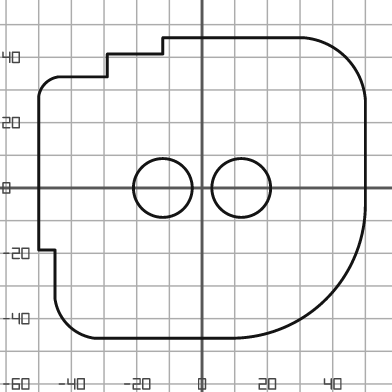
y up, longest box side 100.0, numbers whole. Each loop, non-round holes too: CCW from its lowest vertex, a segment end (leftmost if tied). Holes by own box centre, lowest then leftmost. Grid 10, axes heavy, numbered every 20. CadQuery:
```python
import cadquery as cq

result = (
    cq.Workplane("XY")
    .moveTo(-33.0, -46.0)
    .lineTo(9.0, -46.0)
    .threePointArc((38.0, -34.0), (50.0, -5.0))
    .lineTo(50.0, 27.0)
    .threePointArc((44.0, 40.0), (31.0, 46.0))
    .lineTo(-12.0, 46.0)
    .lineTo(-12.0, 41.0)
    .lineTo(-29.0, 41.0)
    .lineTo(-29.0, 34.0)
    .lineTo(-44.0, 34.0)
    .threePointArc((-48.0, 32.0), (-50.0, 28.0))
    .lineTo(-50.0, -19.0)
    .lineTo(-45.0, -19.0)
    .lineTo(-45.0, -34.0)
    .threePointArc((-41.0, -42.0), (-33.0, -46.0))
    .close()
    .moveTo(-12.0, 0.0)
    .circle(9.0)
    .moveTo(12.0, 0.0)
    .circle(9.0)
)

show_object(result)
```